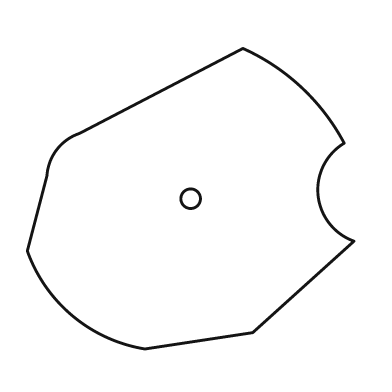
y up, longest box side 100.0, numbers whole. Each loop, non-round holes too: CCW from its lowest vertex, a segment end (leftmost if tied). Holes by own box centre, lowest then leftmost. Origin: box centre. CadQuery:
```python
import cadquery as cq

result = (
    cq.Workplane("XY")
    .moveTo(-14.0, -46.0)
    .lineTo(19.0, -41.0)
    .lineTo(50.0, -13.0)
    .threePointArc((39.0, 1.0), (47.0, 17.0))
    .threePointArc((34.0, 34.0), (16.0, 46.0))
    .lineTo(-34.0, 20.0)
    .threePointArc((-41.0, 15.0), (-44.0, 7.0))
    .lineTo(-50.0, -16.0)
    .threePointArc((-36.0, -36.0), (-14.0, -46.0))
    .close()
    .moveTo(0.0, 0.0)
    .circle(3.0)
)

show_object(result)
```